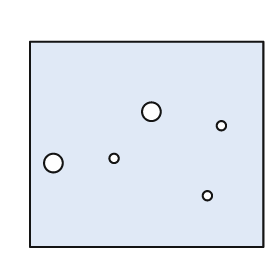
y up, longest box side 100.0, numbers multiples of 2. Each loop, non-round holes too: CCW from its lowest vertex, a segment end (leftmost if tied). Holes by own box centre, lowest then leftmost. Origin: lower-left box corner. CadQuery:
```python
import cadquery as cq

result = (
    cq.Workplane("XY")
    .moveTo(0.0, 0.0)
    .lineTo(100.0, 0.0)
    .lineTo(100.0, 88.0)
    .lineTo(0.0, 88.0)
    .close()
    .moveTo(76.0, 22.0)
    .circle(2.0)
    .moveTo(10.0, 36.0)
    .circle(4.0)
    .moveTo(36.0, 38.0)
    .circle(2.0)
    .moveTo(82.0, 52.0)
    .circle(2.0)
    .moveTo(52.0, 58.0)
    .circle(4.0)
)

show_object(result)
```